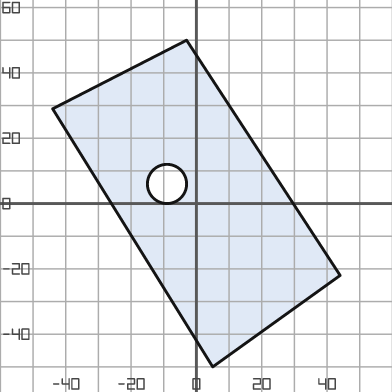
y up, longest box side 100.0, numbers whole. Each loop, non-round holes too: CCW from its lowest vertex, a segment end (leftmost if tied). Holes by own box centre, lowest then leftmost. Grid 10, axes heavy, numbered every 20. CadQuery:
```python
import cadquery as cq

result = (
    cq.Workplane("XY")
    .moveTo(5.0, -50.0)
    .lineTo(44.0, -22.0)
    .lineTo(-3.0, 50.0)
    .lineTo(-44.0, 29.0)
    .close()
    .moveTo(-9.0, 6.0)
    .circle(6.0)
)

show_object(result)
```